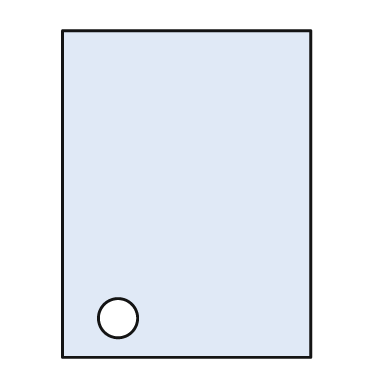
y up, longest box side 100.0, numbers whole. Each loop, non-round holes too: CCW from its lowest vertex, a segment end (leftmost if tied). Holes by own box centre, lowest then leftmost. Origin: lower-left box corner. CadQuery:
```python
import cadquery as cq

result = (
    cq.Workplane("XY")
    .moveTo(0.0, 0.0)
    .lineTo(76.0, 0.0)
    .lineTo(76.0, 100.0)
    .lineTo(0.0, 100.0)
    .close()
    .moveTo(17.0, 12.0)
    .circle(6.0)
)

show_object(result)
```